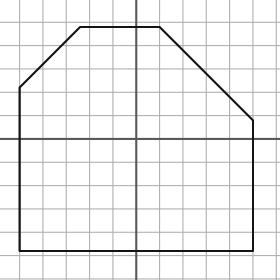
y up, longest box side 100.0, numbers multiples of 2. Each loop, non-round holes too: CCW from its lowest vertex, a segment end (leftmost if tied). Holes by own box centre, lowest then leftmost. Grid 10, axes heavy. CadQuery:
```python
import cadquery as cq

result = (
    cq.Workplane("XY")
    .moveTo(-50.0, -48.0)
    .lineTo(50.0, -48.0)
    .lineTo(50.0, 8.0)
    .lineTo(10.0, 48.0)
    .lineTo(-24.0, 48.0)
    .lineTo(-50.0, 22.0)
    .close()
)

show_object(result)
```